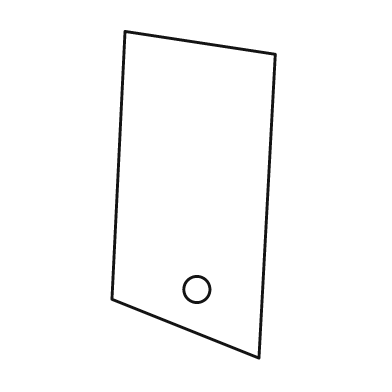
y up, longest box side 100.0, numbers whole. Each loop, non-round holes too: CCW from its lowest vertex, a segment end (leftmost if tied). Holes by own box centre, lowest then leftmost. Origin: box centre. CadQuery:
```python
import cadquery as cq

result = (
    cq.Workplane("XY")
    .moveTo(20.0, -50.0)
    .lineTo(25.0, 43.0)
    .lineTo(-21.0, 50.0)
    .lineTo(-25.0, -32.0)
    .close()
    .moveTo(1.0, -29.0)
    .circle(4.0)
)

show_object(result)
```